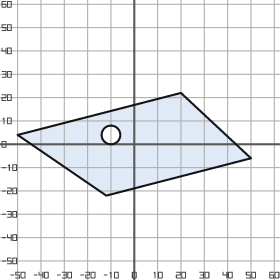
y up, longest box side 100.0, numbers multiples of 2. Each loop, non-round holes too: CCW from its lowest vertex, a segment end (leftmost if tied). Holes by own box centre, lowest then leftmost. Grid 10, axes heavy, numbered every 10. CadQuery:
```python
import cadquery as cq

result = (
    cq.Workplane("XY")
    .moveTo(-12.0, -22.0)
    .lineTo(50.0, -6.0)
    .lineTo(20.0, 22.0)
    .lineTo(-50.0, 4.0)
    .close()
    .moveTo(-10.0, 4.0)
    .circle(4.0)
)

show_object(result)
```